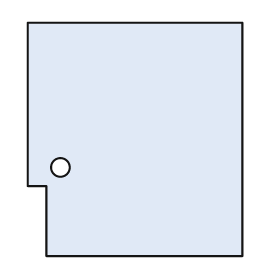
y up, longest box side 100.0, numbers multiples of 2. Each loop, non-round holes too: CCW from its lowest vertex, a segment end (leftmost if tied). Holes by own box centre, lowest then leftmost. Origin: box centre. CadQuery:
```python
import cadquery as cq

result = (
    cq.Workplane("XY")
    .moveTo(-38.0, -50.0)
    .lineTo(46.0, -50.0)
    .lineTo(46.0, 50.0)
    .lineTo(-46.0, 50.0)
    .lineTo(-46.0, -20.0)
    .lineTo(-38.0, -20.0)
    .close()
    .moveTo(-32.0, -12.0)
    .circle(4.0)
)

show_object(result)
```